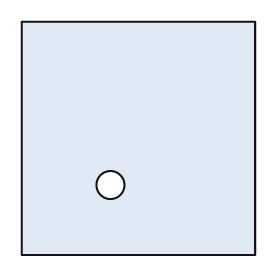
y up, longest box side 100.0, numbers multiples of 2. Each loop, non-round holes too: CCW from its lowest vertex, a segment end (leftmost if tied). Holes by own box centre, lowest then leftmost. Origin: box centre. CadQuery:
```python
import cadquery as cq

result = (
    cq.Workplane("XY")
    .moveTo(-50.0, -50.0)
    .lineTo(50.0, -50.0)
    .lineTo(50.0, 50.0)
    .lineTo(-50.0, 50.0)
    .close()
    .moveTo(-12.0, -20.0)
    .circle(6.0)
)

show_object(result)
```